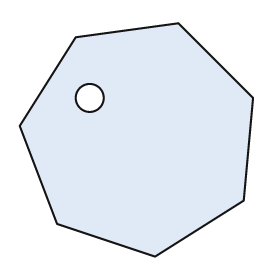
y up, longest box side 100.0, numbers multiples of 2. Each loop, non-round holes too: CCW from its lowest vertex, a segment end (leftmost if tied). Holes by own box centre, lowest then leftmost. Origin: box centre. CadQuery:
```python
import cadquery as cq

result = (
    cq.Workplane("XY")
    .moveTo(8.0, -50.0)
    .lineTo(46.0, -26.0)
    .lineTo(50.0, 18.0)
    .lineTo(18.0, 50.0)
    .lineTo(-26.0, 44.0)
    .lineTo(-50.0, 6.0)
    .lineTo(-34.0, -36.0)
    .close()
    .moveTo(-20.0, 18.0)
    .circle(6.0)
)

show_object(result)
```